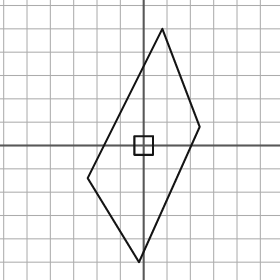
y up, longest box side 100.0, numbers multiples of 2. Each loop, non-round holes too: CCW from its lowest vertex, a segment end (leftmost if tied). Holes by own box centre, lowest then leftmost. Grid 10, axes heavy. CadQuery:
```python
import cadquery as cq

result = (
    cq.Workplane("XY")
    .moveTo(-2.0, -50.0)
    .lineTo(24.0, 8.0)
    .lineTo(8.0, 50.0)
    .lineTo(-24.0, -14.0)
    .close()
    .moveTo(-4.0, -4.0)
    .lineTo(4.0, -4.0)
    .lineTo(4.0, 4.0)
    .lineTo(-4.0, 4.0)
    .close()
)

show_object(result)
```